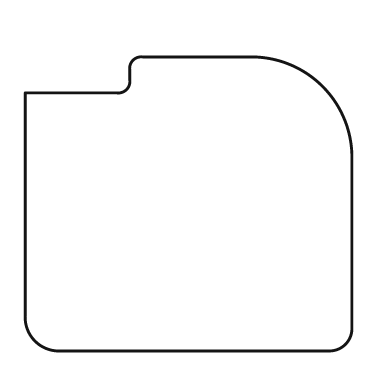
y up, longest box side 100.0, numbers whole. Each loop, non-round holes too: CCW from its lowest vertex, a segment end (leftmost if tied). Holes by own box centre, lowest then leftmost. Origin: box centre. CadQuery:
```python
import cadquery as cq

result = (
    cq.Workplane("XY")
    .moveTo(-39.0, -45.0)
    .lineTo(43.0, -45.0)
    .threePointArc((48.0, -43.0), (50.0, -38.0))
    .lineTo(50.0, 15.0)
    .threePointArc((41.0, 36.0), (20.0, 45.0))
    .lineTo(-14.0, 45.0)
    .threePointArc((-17.0, 44.0), (-18.0, 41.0))
    .lineTo(-18.0, 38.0)
    .threePointArc((-19.0, 35.0), (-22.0, 34.0))
    .lineTo(-50.0, 34.0)
    .lineTo(-50.0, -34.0)
    .threePointArc((-47.0, -42.0), (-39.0, -45.0))
    .close()
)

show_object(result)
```